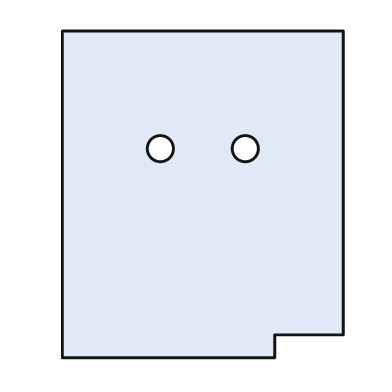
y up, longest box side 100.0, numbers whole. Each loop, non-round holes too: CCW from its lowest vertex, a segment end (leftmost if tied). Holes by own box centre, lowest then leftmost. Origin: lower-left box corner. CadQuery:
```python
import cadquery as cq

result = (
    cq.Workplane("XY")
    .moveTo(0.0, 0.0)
    .lineTo(65.0, 0.0)
    .lineTo(65.0, 7.0)
    .lineTo(86.0, 7.0)
    .lineTo(86.0, 100.0)
    .lineTo(0.0, 100.0)
    .close()
    .moveTo(30.0, 64.0)
    .circle(4.0)
    .moveTo(56.0, 64.0)
    .circle(4.0)
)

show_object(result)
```